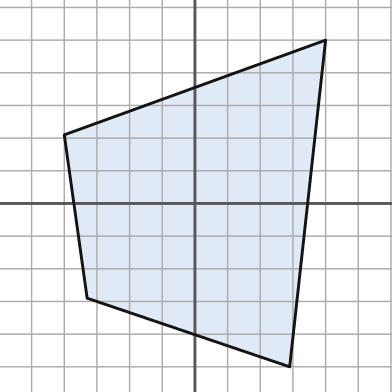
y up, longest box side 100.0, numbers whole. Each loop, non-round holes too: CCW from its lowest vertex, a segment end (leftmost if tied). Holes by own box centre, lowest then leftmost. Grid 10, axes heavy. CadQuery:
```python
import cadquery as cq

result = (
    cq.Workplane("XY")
    .moveTo(29.0, -50.0)
    .lineTo(40.0, 50.0)
    .lineTo(-40.0, 21.0)
    .lineTo(-33.0, -29.0)
    .close()
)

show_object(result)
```